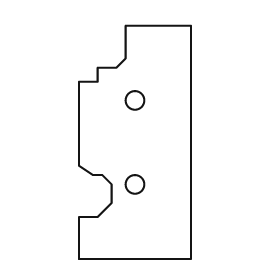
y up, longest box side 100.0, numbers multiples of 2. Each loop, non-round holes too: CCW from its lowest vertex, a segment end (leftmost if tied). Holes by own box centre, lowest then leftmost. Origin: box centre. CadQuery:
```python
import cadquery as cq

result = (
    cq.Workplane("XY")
    .moveTo(-24.0, -50.0)
    .lineTo(24.0, -50.0)
    .lineTo(24.0, 50.0)
    .lineTo(-4.0, 50.0)
    .lineTo(-4.0, 36.0)
    .lineTo(-8.0, 32.0)
    .lineTo(-16.0, 32.0)
    .lineTo(-16.0, 26.0)
    .lineTo(-24.0, 26.0)
    .lineTo(-24.0, -10.0)
    .lineTo(-18.0, -14.0)
    .lineTo(-14.0, -14.0)
    .lineTo(-10.0, -18.0)
    .lineTo(-10.0, -26.0)
    .lineTo(-16.0, -32.0)
    .lineTo(-24.0, -32.0)
    .close()
    .moveTo(0.0, -18.0)
    .circle(4.0)
    .moveTo(0.0, 18.0)
    .circle(4.0)
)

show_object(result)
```